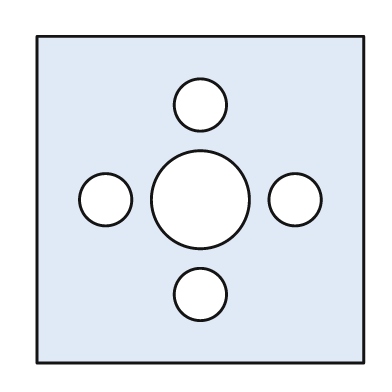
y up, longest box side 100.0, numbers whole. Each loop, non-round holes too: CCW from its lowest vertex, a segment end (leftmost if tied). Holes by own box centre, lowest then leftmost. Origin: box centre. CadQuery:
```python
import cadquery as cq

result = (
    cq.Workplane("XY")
    .moveTo(-50.0, -50.0)
    .lineTo(50.0, -50.0)
    .lineTo(50.0, 50.0)
    .lineTo(-50.0, 50.0)
    .close()
    .moveTo(0.0, -29.0)
    .circle(8.0)
    .moveTo(-29.0, 0.0)
    .circle(8.0)
    .moveTo(0.0, 0.0)
    .circle(15.0)
    .moveTo(29.0, 0.0)
    .circle(8.0)
    .moveTo(0.0, 29.0)
    .circle(8.0)
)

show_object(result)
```